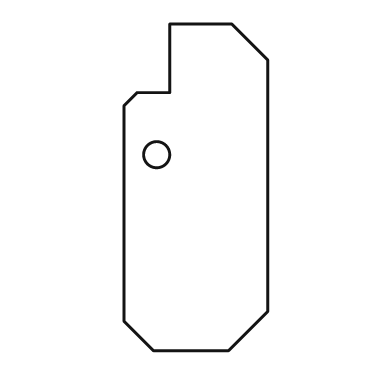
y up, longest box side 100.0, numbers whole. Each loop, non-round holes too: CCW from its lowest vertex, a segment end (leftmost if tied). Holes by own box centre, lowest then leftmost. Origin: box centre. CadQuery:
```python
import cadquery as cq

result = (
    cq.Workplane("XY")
    .moveTo(-13.0, -50.0)
    .lineTo(10.0, -50.0)
    .lineTo(22.0, -38.0)
    .lineTo(22.0, 39.0)
    .lineTo(11.0, 50.0)
    .lineTo(-8.0, 50.0)
    .lineTo(-8.0, 29.0)
    .lineTo(-18.0, 29.0)
    .lineTo(-22.0, 25.0)
    .lineTo(-22.0, -41.0)
    .close()
    .moveTo(-12.0, 10.0)
    .circle(4.0)
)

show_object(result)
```